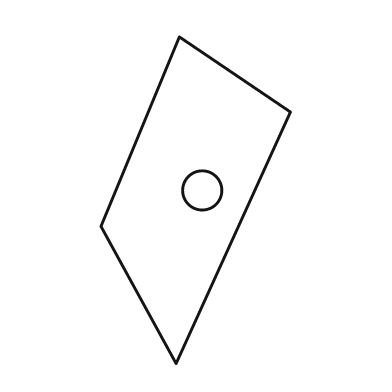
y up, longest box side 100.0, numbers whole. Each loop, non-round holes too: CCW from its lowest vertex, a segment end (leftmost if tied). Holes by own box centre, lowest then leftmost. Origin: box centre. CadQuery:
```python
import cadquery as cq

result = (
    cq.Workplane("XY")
    .moveTo(-6.0, -50.0)
    .lineTo(29.0, 27.0)
    .lineTo(-5.0, 50.0)
    .lineTo(-29.0, -8.0)
    .close()
    .moveTo(2.0, 3.0)
    .circle(6.0)
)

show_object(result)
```